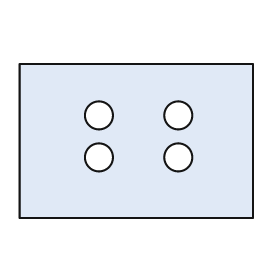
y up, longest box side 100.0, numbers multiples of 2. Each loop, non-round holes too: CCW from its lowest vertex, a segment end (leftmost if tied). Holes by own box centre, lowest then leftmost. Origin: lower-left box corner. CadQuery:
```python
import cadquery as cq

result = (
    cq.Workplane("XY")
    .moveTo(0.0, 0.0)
    .lineTo(100.0, 0.0)
    .lineTo(100.0, 66.0)
    .lineTo(0.0, 66.0)
    .close()
    .moveTo(34.0, 26.0)
    .circle(6.0)
    .moveTo(68.0, 26.0)
    .circle(6.0)
    .moveTo(34.0, 44.0)
    .circle(6.0)
    .moveTo(68.0, 44.0)
    .circle(6.0)
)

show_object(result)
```